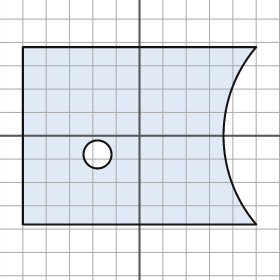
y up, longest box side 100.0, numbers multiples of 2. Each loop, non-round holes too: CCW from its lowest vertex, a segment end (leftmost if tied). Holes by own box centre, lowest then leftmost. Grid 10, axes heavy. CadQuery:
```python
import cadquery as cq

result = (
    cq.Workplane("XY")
    .moveTo(-50.0, -38.0)
    .lineTo(50.0, -38.0)
    .threePointArc((36.0, 0.0), (50.0, 38.0))
    .lineTo(-50.0, 38.0)
    .close()
    .moveTo(-18.0, -8.0)
    .circle(6.0)
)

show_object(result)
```